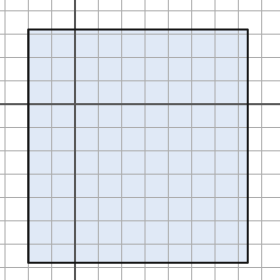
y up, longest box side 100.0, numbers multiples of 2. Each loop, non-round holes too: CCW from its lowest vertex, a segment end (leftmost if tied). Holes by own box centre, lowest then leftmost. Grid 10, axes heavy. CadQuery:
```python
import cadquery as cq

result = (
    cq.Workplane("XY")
    .moveTo(-20.0, -68.0)
    .lineTo(74.0, -68.0)
    .lineTo(74.0, 32.0)
    .lineTo(-20.0, 32.0)
    .close()
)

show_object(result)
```